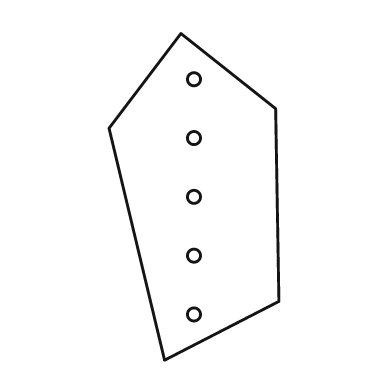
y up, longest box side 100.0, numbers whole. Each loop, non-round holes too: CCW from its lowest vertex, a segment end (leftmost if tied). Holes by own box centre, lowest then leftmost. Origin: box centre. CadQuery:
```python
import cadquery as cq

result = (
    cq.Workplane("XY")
    .moveTo(-9.0, -50.0)
    .lineTo(26.0, -32.0)
    .lineTo(25.0, 27.0)
    .lineTo(-4.0, 50.0)
    .lineTo(-26.0, 21.0)
    .close()
    .moveTo(0.0, -36.0)
    .circle(2.0)
    .moveTo(0.0, -18.0)
    .circle(2.0)
    .moveTo(0.0, 0.0)
    .circle(2.0)
    .moveTo(0.0, 18.0)
    .circle(2.0)
    .moveTo(0.0, 36.0)
    .circle(2.0)
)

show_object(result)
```